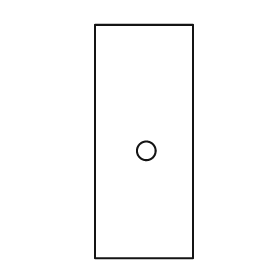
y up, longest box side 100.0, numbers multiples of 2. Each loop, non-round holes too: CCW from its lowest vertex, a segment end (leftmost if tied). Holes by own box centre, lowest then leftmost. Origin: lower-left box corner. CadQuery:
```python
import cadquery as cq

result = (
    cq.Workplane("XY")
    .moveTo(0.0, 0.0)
    .lineTo(42.0, 0.0)
    .lineTo(42.0, 100.0)
    .lineTo(0.0, 100.0)
    .close()
    .moveTo(22.0, 46.0)
    .circle(4.0)
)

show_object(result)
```